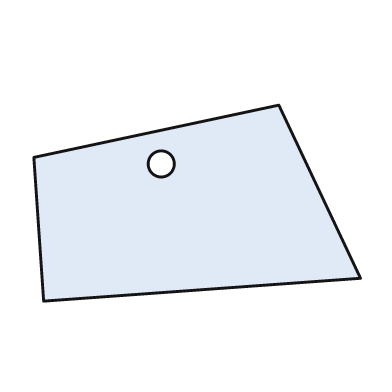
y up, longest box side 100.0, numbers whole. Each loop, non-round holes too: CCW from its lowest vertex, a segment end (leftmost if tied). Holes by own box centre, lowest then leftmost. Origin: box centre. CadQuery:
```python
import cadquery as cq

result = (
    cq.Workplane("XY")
    .moveTo(-47.0, -30.0)
    .lineTo(50.0, -23.0)
    .lineTo(25.0, 30.0)
    .lineTo(-50.0, 14.0)
    .close()
    .moveTo(-11.0, 12.0)
    .circle(4.0)
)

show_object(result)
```